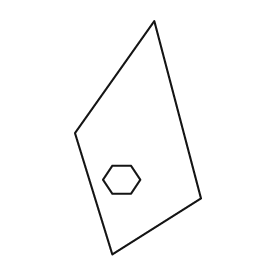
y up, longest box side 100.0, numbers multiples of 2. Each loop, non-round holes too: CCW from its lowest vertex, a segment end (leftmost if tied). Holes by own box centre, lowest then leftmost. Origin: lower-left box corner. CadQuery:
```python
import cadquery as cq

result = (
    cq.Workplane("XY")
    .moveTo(16.0, 0.0)
    .lineTo(54.0, 24.0)
    .lineTo(34.0, 100.0)
    .lineTo(0.0, 52.0)
    .close()
    .moveTo(16.0, 26.0)
    .lineTo(24.0, 26.0)
    .lineTo(28.0, 32.0)
    .lineTo(24.0, 38.0)
    .lineTo(16.0, 38.0)
    .lineTo(12.0, 32.0)
    .close()
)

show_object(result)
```